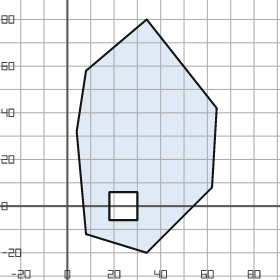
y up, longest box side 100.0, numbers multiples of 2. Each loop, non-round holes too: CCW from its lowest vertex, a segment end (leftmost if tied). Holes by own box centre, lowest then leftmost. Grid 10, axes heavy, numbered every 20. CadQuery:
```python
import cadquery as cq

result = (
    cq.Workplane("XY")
    .moveTo(34.0, -20.0)
    .lineTo(62.0, 8.0)
    .lineTo(64.0, 42.0)
    .lineTo(34.0, 80.0)
    .lineTo(8.0, 58.0)
    .lineTo(4.0, 32.0)
    .lineTo(8.0, -12.0)
    .close()
    .moveTo(18.0, -6.0)
    .lineTo(30.0, -6.0)
    .lineTo(30.0, 6.0)
    .lineTo(18.0, 6.0)
    .close()
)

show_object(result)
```